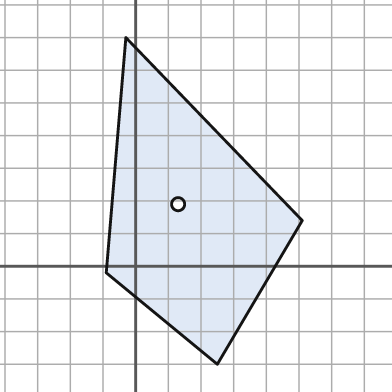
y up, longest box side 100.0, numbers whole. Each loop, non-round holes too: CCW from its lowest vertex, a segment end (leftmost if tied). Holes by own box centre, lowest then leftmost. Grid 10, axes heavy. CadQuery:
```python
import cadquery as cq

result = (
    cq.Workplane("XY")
    .moveTo(25.0, -30.0)
    .lineTo(51.0, 14.0)
    .lineTo(-3.0, 70.0)
    .lineTo(-9.0, -2.0)
    .close()
    .moveTo(13.0, 19.0)
    .circle(2.0)
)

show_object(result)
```